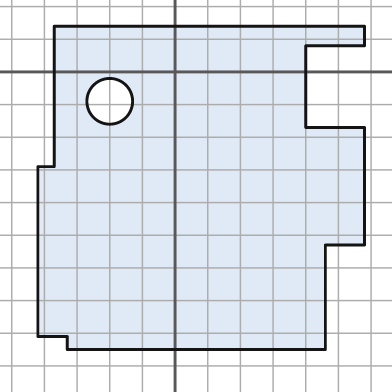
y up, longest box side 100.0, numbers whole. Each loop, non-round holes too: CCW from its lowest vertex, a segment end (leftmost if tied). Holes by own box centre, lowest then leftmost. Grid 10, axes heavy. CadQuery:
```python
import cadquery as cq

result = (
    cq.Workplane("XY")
    .moveTo(-33.0, -85.0)
    .lineTo(46.0, -85.0)
    .lineTo(46.0, -53.0)
    .lineTo(58.0, -53.0)
    .lineTo(58.0, -17.0)
    .lineTo(40.0, -17.0)
    .lineTo(40.0, 8.0)
    .lineTo(58.0, 8.0)
    .lineTo(58.0, 14.0)
    .lineTo(-37.0, 14.0)
    .lineTo(-37.0, -29.0)
    .lineTo(-42.0, -29.0)
    .lineTo(-42.0, -81.0)
    .lineTo(-33.0, -81.0)
    .close()
    .moveTo(-20.0, -9.0)
    .circle(7.0)
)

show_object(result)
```